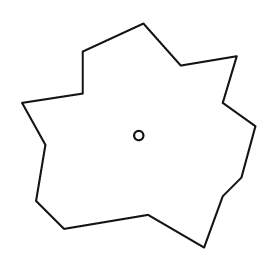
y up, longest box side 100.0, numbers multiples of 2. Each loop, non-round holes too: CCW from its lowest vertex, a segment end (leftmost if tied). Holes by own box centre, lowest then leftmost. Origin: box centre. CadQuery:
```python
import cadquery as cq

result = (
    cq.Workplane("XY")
    .moveTo(28.0, -48.0)
    .lineTo(36.0, -26.0)
    .lineTo(44.0, -18.0)
    .lineTo(50.0, 4.0)
    .lineTo(36.0, 14.0)
    .lineTo(42.0, 34.0)
    .lineTo(18.0, 30.0)
    .lineTo(2.0, 48.0)
    .lineTo(-24.0, 36.0)
    .lineTo(-24.0, 18.0)
    .lineTo(-50.0, 14.0)
    .lineTo(-40.0, -4.0)
    .lineTo(-44.0, -28.0)
    .lineTo(-32.0, -40.0)
    .lineTo(4.0, -34.0)
    .close()
    .moveTo(0.0, 0.0)
    .circle(2.0)
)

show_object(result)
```